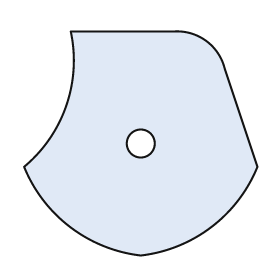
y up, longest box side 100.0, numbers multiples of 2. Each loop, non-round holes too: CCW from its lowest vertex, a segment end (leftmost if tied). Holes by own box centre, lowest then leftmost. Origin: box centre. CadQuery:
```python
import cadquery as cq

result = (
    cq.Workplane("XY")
    .moveTo(0.0, -48.0)
    .threePointArc((30.0, -36.0), (50.0, -10.0))
    .lineTo(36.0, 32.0)
    .threePointArc((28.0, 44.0), (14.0, 48.0))
    .lineTo(-30.0, 48.0)
    .threePointArc((-32.0, 16.0), (-50.0, -10.0))
    .threePointArc((-30.0, -36.0), (0.0, -48.0))
    .close()
    .moveTo(0.0, 0.0)
    .circle(6.0)
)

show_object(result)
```